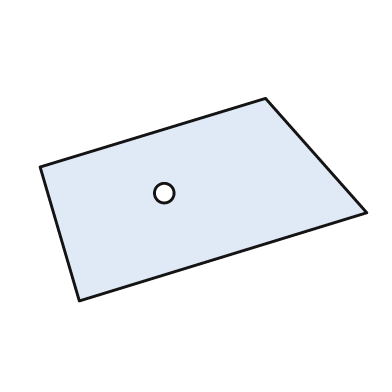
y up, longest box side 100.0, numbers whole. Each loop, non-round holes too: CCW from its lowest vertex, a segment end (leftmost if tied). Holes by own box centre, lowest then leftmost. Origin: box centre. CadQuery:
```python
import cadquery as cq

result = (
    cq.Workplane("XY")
    .moveTo(-38.0, -31.0)
    .lineTo(50.0, -4.0)
    .lineTo(19.0, 31.0)
    .lineTo(-50.0, 10.0)
    .close()
    .moveTo(-12.0, 2.0)
    .circle(3.0)
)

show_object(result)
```